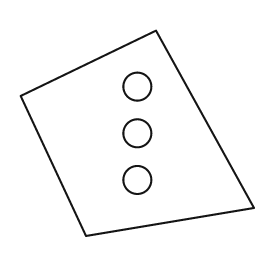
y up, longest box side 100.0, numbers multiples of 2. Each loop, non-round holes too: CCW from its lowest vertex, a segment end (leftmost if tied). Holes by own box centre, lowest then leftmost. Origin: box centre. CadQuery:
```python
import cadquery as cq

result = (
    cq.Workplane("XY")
    .moveTo(-22.0, -44.0)
    .lineTo(50.0, -32.0)
    .lineTo(8.0, 44.0)
    .lineTo(-50.0, 16.0)
    .close()
    .moveTo(0.0, -20.0)
    .circle(6.0)
    .moveTo(0.0, 0.0)
    .circle(6.0)
    .moveTo(0.0, 20.0)
    .circle(6.0)
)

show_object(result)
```